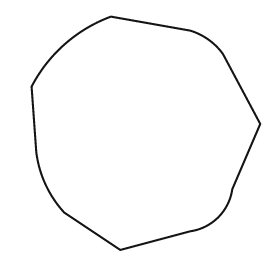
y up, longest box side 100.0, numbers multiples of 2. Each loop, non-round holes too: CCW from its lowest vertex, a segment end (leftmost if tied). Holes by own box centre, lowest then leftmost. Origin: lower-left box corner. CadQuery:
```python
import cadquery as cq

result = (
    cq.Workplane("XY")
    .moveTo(38.0, 0.0)
    .lineTo(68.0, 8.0)
    .threePointArc((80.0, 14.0), (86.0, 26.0))
    .lineTo(98.0, 54.0)
    .lineTo(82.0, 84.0)
    .threePointArc((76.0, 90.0), (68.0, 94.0))
    .lineTo(34.0, 100.0)
    .threePointArc((14.0, 88.0), (0.0, 70.0))
    .lineTo(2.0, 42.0)
    .threePointArc((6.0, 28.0), (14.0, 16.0))
    .close()
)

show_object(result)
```